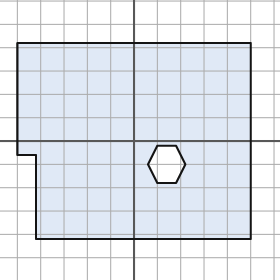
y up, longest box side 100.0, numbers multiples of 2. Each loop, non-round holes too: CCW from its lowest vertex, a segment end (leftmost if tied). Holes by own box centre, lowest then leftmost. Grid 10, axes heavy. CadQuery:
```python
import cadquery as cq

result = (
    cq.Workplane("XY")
    .moveTo(-42.0, -42.0)
    .lineTo(50.0, -42.0)
    .lineTo(50.0, 42.0)
    .lineTo(-50.0, 42.0)
    .lineTo(-50.0, -6.0)
    .lineTo(-42.0, -6.0)
    .close()
    .moveTo(10.0, -18.0)
    .lineTo(18.0, -18.0)
    .lineTo(22.0, -10.0)
    .lineTo(18.0, -2.0)
    .lineTo(10.0, -2.0)
    .lineTo(6.0, -10.0)
    .close()
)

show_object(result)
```